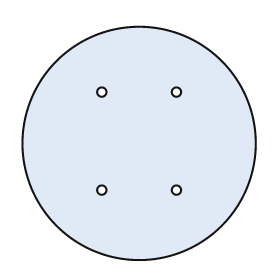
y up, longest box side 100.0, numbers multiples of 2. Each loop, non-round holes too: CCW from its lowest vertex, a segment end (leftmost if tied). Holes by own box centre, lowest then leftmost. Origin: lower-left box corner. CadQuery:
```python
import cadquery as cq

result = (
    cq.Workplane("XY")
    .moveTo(50.0, 50.0)
    .circle(50.0)
    .moveTo(34.0, 30.0)
    .circle(2.0)
    .moveTo(66.0, 30.0)
    .circle(2.0)
    .moveTo(34.0, 72.0)
    .circle(2.0)
    .moveTo(66.0, 72.0)
    .circle(2.0)
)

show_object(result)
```